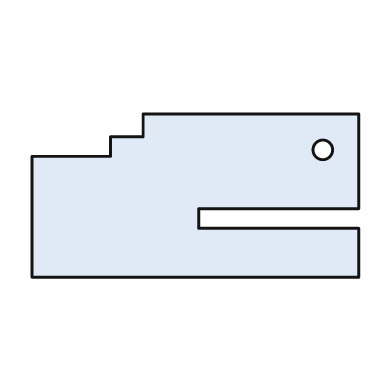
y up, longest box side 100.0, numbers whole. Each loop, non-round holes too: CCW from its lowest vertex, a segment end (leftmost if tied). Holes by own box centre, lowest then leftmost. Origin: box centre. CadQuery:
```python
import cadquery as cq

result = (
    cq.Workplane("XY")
    .moveTo(-50.0, -25.0)
    .lineTo(50.0, -25.0)
    .lineTo(50.0, -10.0)
    .lineTo(1.0, -10.0)
    .lineTo(1.0, -4.0)
    .lineTo(50.0, -4.0)
    .lineTo(50.0, 25.0)
    .lineTo(-16.0, 25.0)
    .lineTo(-16.0, 18.0)
    .lineTo(-26.0, 18.0)
    .lineTo(-26.0, 12.0)
    .lineTo(-50.0, 12.0)
    .close()
    .moveTo(39.0, 14.0)
    .circle(3.0)
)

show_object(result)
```